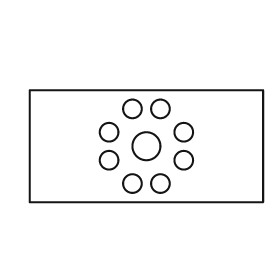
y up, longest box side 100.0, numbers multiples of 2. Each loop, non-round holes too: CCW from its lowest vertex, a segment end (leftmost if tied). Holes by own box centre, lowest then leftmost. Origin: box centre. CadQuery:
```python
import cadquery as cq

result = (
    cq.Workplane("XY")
    .moveTo(-50.0, -24.0)
    .lineTo(50.0, -24.0)
    .lineTo(50.0, 24.0)
    .lineTo(-50.0, 24.0)
    .close()
    .moveTo(-6.0, -16.0)
    .circle(4.0)
    .moveTo(6.0, -16.0)
    .circle(4.0)
    .moveTo(-16.0, -6.0)
    .circle(4.0)
    .moveTo(16.0, -6.0)
    .circle(4.0)
    .moveTo(0.0, 0.0)
    .circle(6.0)
    .moveTo(-16.0, 6.0)
    .circle(4.0)
    .moveTo(16.0, 6.0)
    .circle(4.0)
    .moveTo(-6.0, 16.0)
    .circle(4.0)
    .moveTo(6.0, 16.0)
    .circle(4.0)
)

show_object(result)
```